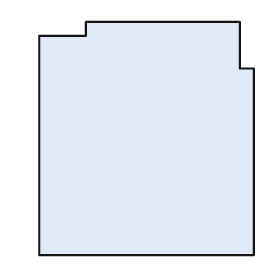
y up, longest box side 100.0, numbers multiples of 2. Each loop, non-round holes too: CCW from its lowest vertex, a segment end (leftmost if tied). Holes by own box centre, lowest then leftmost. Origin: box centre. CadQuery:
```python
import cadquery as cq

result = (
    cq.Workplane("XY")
    .moveTo(-46.0, -50.0)
    .lineTo(46.0, -50.0)
    .lineTo(46.0, 30.0)
    .lineTo(40.0, 30.0)
    .lineTo(40.0, 50.0)
    .lineTo(-26.0, 50.0)
    .lineTo(-26.0, 44.0)
    .lineTo(-46.0, 44.0)
    .close()
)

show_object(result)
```